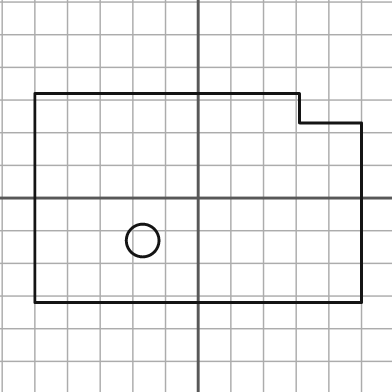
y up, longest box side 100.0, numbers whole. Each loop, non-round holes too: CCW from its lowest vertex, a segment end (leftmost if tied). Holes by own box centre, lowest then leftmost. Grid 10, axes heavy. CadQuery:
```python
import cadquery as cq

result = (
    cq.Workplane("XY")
    .moveTo(-50.0, -32.0)
    .lineTo(50.0, -32.0)
    .lineTo(50.0, 23.0)
    .lineTo(31.0, 23.0)
    .lineTo(31.0, 32.0)
    .lineTo(-50.0, 32.0)
    .close()
    .moveTo(-17.0, -13.0)
    .circle(5.0)
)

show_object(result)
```